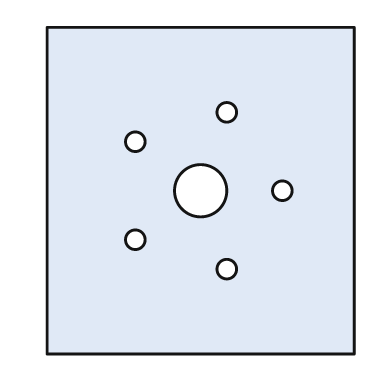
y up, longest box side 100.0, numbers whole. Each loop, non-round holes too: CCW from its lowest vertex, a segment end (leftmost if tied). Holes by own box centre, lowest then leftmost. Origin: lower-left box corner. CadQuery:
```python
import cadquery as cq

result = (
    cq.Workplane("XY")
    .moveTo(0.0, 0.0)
    .lineTo(94.0, 0.0)
    .lineTo(94.0, 100.0)
    .lineTo(0.0, 100.0)
    .close()
    .moveTo(55.0, 26.0)
    .circle(3.0)
    .moveTo(27.0, 35.0)
    .circle(3.0)
    .moveTo(47.0, 50.0)
    .circle(8.0)
    .moveTo(72.0, 50.0)
    .circle(3.0)
    .moveTo(27.0, 65.0)
    .circle(3.0)
    .moveTo(55.0, 74.0)
    .circle(3.0)
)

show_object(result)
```